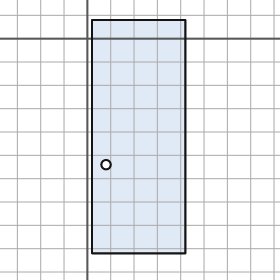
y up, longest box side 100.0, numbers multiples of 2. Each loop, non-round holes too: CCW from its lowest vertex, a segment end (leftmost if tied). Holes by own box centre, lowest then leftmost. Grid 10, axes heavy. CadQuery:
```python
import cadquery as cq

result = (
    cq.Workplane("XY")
    .moveTo(2.0, -92.0)
    .lineTo(42.0, -92.0)
    .lineTo(42.0, 8.0)
    .lineTo(2.0, 8.0)
    .close()
    .moveTo(8.0, -54.0)
    .circle(2.0)
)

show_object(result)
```